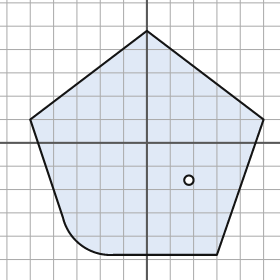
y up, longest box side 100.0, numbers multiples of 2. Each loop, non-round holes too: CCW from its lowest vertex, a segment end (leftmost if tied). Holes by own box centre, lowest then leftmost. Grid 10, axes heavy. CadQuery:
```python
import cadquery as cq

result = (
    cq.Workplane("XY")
    .moveTo(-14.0, -48.0)
    .lineTo(30.0, -48.0)
    .lineTo(50.0, 10.0)
    .lineTo(0.0, 48.0)
    .lineTo(-50.0, 10.0)
    .lineTo(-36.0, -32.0)
    .threePointArc((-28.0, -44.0), (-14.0, -48.0))
    .close()
    .moveTo(18.0, -16.0)
    .circle(2.0)
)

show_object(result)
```